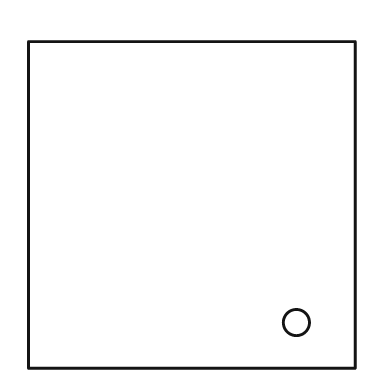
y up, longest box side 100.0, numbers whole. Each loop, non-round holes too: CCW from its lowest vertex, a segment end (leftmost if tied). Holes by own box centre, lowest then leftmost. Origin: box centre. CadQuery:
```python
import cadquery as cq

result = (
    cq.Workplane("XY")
    .moveTo(-50.0, -50.0)
    .lineTo(50.0, -50.0)
    .lineTo(50.0, 50.0)
    .lineTo(-50.0, 50.0)
    .close()
    .moveTo(32.0, -36.0)
    .circle(4.0)
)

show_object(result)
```